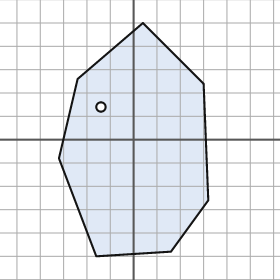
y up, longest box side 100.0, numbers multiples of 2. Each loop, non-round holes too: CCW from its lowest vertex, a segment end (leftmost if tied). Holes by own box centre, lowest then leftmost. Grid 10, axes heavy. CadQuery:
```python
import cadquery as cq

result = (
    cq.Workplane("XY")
    .moveTo(-16.0, -50.0)
    .lineTo(16.0, -48.0)
    .lineTo(32.0, -26.0)
    .lineTo(30.0, 24.0)
    .lineTo(4.0, 50.0)
    .lineTo(-24.0, 26.0)
    .lineTo(-32.0, -8.0)
    .close()
    .moveTo(-14.0, 14.0)
    .circle(2.0)
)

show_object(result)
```